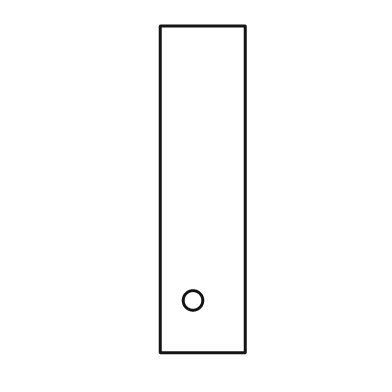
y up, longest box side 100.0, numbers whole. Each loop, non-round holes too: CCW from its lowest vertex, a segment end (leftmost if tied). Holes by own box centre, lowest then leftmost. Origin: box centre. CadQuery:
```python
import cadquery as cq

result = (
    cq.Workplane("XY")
    .moveTo(-13.0, -50.0)
    .lineTo(13.0, -50.0)
    .lineTo(13.0, 50.0)
    .lineTo(-13.0, 50.0)
    .close()
    .moveTo(-3.0, -34.0)
    .circle(3.0)
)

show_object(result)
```